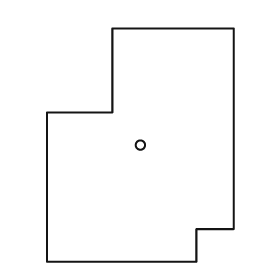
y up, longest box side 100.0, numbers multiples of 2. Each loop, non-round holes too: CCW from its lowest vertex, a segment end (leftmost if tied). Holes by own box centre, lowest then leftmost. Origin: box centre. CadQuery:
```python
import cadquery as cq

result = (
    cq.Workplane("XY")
    .moveTo(-40.0, -50.0)
    .lineTo(24.0, -50.0)
    .lineTo(24.0, -36.0)
    .lineTo(40.0, -36.0)
    .lineTo(40.0, 50.0)
    .lineTo(-12.0, 50.0)
    .lineTo(-12.0, 14.0)
    .lineTo(-40.0, 14.0)
    .close()
    .moveTo(0.0, 0.0)
    .circle(2.0)
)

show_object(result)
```